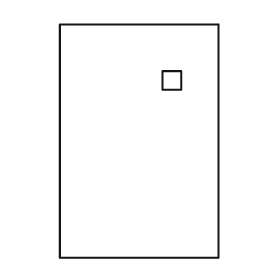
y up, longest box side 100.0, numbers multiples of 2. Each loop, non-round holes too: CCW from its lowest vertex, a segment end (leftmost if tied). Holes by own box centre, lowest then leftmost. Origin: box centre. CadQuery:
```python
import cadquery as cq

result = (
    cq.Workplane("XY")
    .moveTo(-34.0, -50.0)
    .lineTo(34.0, -50.0)
    .lineTo(34.0, 50.0)
    .lineTo(-34.0, 50.0)
    .close()
    .moveTo(10.0, 22.0)
    .lineTo(18.0, 22.0)
    .lineTo(18.0, 30.0)
    .lineTo(10.0, 30.0)
    .close()
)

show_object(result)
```